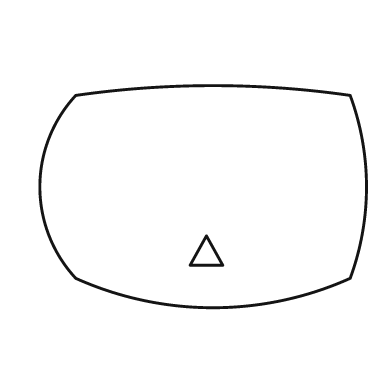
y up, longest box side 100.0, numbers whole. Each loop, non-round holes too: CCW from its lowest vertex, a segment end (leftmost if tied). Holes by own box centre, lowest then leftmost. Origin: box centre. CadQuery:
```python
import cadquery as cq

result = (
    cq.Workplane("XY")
    .moveTo(-39.0, -25.0)
    .threePointArc((3.0, -34.0), (45.0, -25.0))
    .threePointArc((50.0, 3.0), (45.0, 31.0))
    .threePointArc((3.0, 34.0), (-39.0, 31.0))
    .threePointArc((-50.0, 3.0), (-39.0, -25.0))
    .close()
    .moveTo(-4.0, -21.0)
    .lineTo(6.0, -21.0)
    .lineTo(1.0, -12.0)
    .close()
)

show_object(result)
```